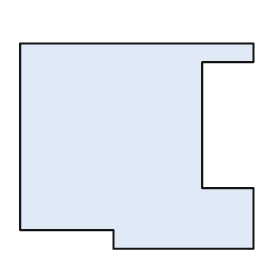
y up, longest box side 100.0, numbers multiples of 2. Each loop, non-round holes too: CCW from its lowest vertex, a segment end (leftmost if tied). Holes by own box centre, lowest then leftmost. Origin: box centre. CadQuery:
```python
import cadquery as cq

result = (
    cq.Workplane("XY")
    .moveTo(-10.0, -44.0)
    .lineTo(50.0, -44.0)
    .lineTo(50.0, -18.0)
    .lineTo(28.0, -18.0)
    .lineTo(28.0, 36.0)
    .lineTo(50.0, 36.0)
    .lineTo(50.0, 44.0)
    .lineTo(-50.0, 44.0)
    .lineTo(-50.0, -36.0)
    .lineTo(-10.0, -36.0)
    .close()
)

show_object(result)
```